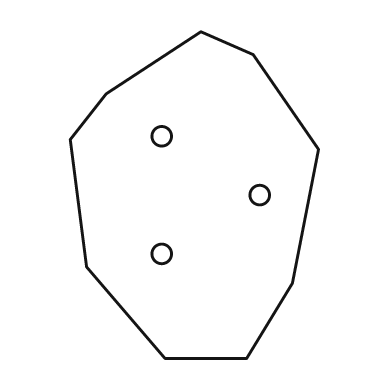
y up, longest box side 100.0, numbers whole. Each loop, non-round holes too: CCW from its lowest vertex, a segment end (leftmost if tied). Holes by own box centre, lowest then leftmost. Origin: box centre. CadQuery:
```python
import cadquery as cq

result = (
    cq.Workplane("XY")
    .moveTo(-9.0, -50.0)
    .lineTo(16.0, -50.0)
    .lineTo(30.0, -27.0)
    .lineTo(38.0, 14.0)
    .lineTo(18.0, 43.0)
    .lineTo(2.0, 50.0)
    .lineTo(-27.0, 31.0)
    .lineTo(-38.0, 17.0)
    .lineTo(-33.0, -22.0)
    .close()
    .moveTo(-10.0, -18.0)
    .circle(3.0)
    .moveTo(20.0, 0.0)
    .circle(3.0)
    .moveTo(-10.0, 18.0)
    .circle(3.0)
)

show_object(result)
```